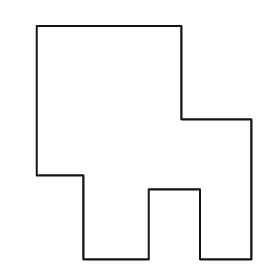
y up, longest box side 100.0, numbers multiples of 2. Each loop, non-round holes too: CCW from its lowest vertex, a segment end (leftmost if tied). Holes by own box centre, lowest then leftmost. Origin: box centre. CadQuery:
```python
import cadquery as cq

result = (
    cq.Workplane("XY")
    .moveTo(-26.0, -50.0)
    .lineTo(2.0, -50.0)
    .lineTo(2.0, -20.0)
    .lineTo(24.0, -20.0)
    .lineTo(24.0, -50.0)
    .lineTo(46.0, -50.0)
    .lineTo(46.0, 10.0)
    .lineTo(16.0, 10.0)
    .lineTo(16.0, 50.0)
    .lineTo(-46.0, 50.0)
    .lineTo(-46.0, -14.0)
    .lineTo(-26.0, -14.0)
    .close()
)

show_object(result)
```